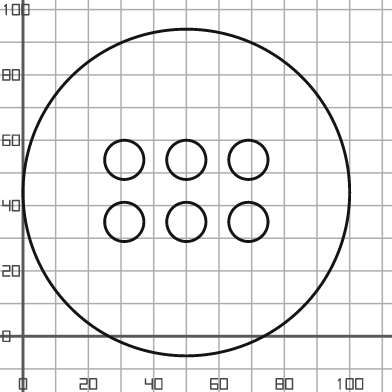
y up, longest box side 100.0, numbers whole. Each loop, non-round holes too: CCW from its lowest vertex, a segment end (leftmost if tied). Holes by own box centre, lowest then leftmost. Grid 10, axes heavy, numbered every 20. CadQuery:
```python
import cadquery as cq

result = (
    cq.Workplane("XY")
    .moveTo(50.0, 44.0)
    .circle(50.0)
    .moveTo(31.0, 35.0)
    .circle(6.0)
    .moveTo(50.0, 35.0)
    .circle(6.0)
    .moveTo(69.0, 35.0)
    .circle(6.0)
    .moveTo(31.0, 54.0)
    .circle(6.0)
    .moveTo(50.0, 54.0)
    .circle(6.0)
    .moveTo(69.0, 54.0)
    .circle(6.0)
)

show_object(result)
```